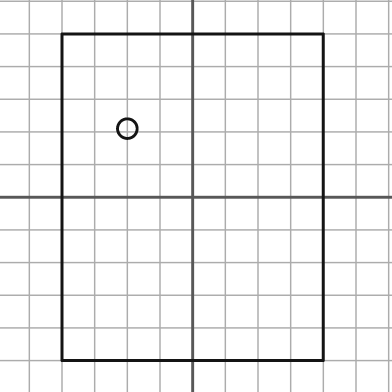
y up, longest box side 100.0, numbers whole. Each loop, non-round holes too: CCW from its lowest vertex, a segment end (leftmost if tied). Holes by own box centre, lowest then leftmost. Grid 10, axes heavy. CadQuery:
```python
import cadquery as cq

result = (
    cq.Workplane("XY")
    .moveTo(-40.0, -50.0)
    .lineTo(40.0, -50.0)
    .lineTo(40.0, 50.0)
    .lineTo(-40.0, 50.0)
    .close()
    .moveTo(-20.0, 21.0)
    .circle(3.0)
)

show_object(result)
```